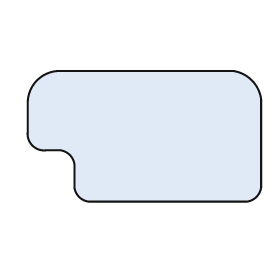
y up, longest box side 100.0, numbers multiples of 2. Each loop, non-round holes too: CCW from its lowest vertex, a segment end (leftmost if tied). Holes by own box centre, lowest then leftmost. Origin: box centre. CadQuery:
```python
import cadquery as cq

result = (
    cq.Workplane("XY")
    .moveTo(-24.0, -28.0)
    .lineTo(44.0, -28.0)
    .threePointArc((48.0, -26.0), (50.0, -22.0))
    .lineTo(50.0, 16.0)
    .threePointArc((46.0, 24.0), (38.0, 28.0))
    .lineTo(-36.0, 28.0)
    .threePointArc((-46.0, 24.0), (-50.0, 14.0))
    .lineTo(-50.0, 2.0)
    .threePointArc((-48.0, -4.0), (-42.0, -6.0))
    .lineTo(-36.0, -6.0)
    .threePointArc((-32.0, -8.0), (-30.0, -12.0))
    .lineTo(-30.0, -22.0)
    .threePointArc((-28.0, -26.0), (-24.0, -28.0))
    .close()
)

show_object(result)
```